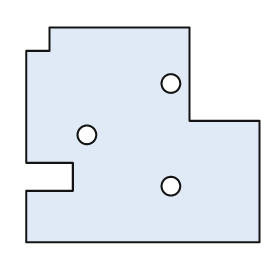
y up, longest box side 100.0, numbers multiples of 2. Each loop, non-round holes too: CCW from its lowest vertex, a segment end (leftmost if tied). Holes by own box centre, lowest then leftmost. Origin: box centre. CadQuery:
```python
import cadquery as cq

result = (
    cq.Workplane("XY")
    .moveTo(-50.0, -46.0)
    .lineTo(50.0, -46.0)
    .lineTo(50.0, 6.0)
    .lineTo(20.0, 6.0)
    .lineTo(20.0, 46.0)
    .lineTo(-40.0, 46.0)
    .lineTo(-40.0, 36.0)
    .lineTo(-50.0, 36.0)
    .lineTo(-50.0, -12.0)
    .lineTo(-30.0, -12.0)
    .lineTo(-30.0, -24.0)
    .lineTo(-50.0, -24.0)
    .close()
    .moveTo(12.0, -22.0)
    .circle(4.0)
    .moveTo(-24.0, 0.0)
    .circle(4.0)
    .moveTo(12.0, 22.0)
    .circle(4.0)
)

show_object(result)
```